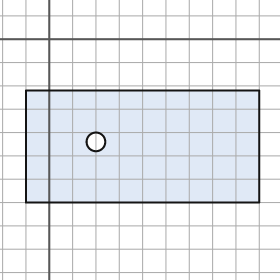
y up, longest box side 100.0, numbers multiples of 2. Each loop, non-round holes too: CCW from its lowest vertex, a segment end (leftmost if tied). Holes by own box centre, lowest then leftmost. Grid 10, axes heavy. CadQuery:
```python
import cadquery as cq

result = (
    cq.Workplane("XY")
    .moveTo(-10.0, -70.0)
    .lineTo(90.0, -70.0)
    .lineTo(90.0, -22.0)
    .lineTo(-10.0, -22.0)
    .close()
    .moveTo(20.0, -44.0)
    .circle(4.0)
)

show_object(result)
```